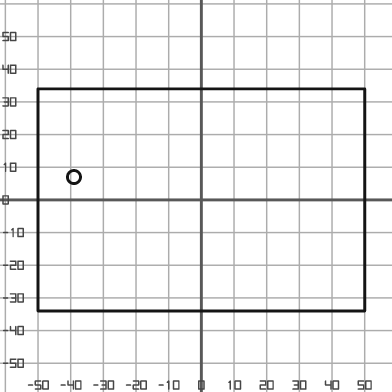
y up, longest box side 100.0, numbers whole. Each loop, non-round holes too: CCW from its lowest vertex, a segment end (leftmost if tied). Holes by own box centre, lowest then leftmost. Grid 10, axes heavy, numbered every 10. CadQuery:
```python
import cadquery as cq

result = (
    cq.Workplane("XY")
    .moveTo(-50.0, -34.0)
    .lineTo(50.0, -34.0)
    .lineTo(50.0, 34.0)
    .lineTo(-50.0, 34.0)
    .close()
    .moveTo(-39.0, 7.0)
    .circle(2.0)
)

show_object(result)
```